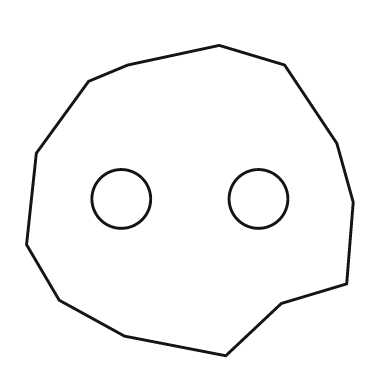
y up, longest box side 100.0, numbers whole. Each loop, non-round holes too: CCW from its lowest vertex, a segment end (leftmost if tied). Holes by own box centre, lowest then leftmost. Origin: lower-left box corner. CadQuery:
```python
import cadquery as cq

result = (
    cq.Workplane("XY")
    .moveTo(61.0, 0.0)
    .lineTo(78.0, 16.0)
    .lineTo(98.0, 22.0)
    .lineTo(100.0, 47.0)
    .lineTo(95.0, 65.0)
    .lineTo(79.0, 89.0)
    .lineTo(59.0, 95.0)
    .lineTo(31.0, 89.0)
    .lineTo(19.0, 84.0)
    .lineTo(3.0, 62.0)
    .lineTo(0.0, 34.0)
    .lineTo(10.0, 17.0)
    .lineTo(30.0, 6.0)
    .close()
    .moveTo(29.0, 48.0)
    .circle(9.0)
    .moveTo(71.0, 48.0)
    .circle(9.0)
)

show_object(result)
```